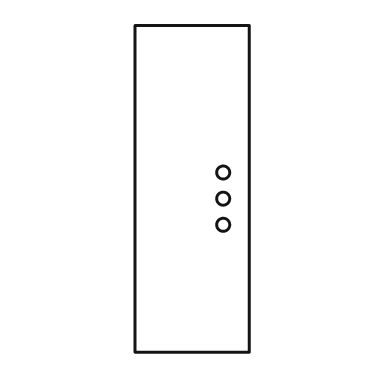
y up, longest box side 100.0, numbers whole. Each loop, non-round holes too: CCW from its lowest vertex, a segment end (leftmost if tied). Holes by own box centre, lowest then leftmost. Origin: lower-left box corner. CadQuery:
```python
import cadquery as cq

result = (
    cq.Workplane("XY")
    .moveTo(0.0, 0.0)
    .lineTo(35.0, 0.0)
    .lineTo(35.0, 100.0)
    .lineTo(0.0, 100.0)
    .close()
    .moveTo(27.0, 39.0)
    .circle(2.0)
    .moveTo(27.0, 47.0)
    .circle(2.0)
    .moveTo(27.0, 55.0)
    .circle(2.0)
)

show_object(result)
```